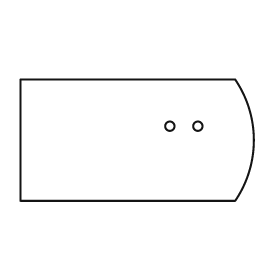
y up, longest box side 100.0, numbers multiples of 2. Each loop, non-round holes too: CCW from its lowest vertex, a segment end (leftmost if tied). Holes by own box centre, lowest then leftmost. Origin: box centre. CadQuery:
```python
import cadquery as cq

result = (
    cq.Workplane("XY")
    .moveTo(-50.0, -26.0)
    .lineTo(42.0, -26.0)
    .threePointArc((50.0, 0.0), (42.0, 26.0))
    .lineTo(-50.0, 26.0)
    .close()
    .moveTo(14.0, 6.0)
    .circle(2.0)
    .moveTo(26.0, 6.0)
    .circle(2.0)
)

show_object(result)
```